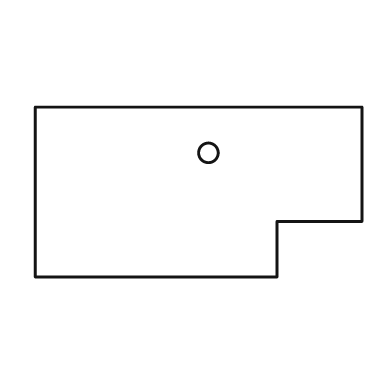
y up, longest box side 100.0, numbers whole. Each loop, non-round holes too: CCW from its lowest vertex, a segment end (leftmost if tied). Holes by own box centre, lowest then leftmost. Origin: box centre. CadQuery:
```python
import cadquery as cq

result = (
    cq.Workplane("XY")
    .moveTo(-50.0, -26.0)
    .lineTo(24.0, -26.0)
    .lineTo(24.0, -9.0)
    .lineTo(50.0, -9.0)
    .lineTo(50.0, 26.0)
    .lineTo(-50.0, 26.0)
    .close()
    .moveTo(3.0, 12.0)
    .circle(3.0)
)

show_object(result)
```